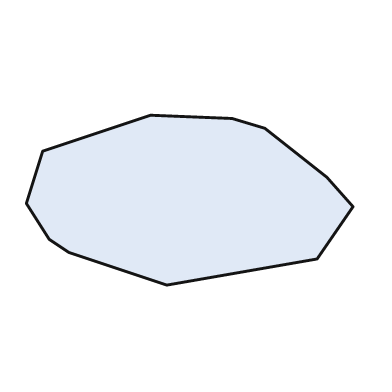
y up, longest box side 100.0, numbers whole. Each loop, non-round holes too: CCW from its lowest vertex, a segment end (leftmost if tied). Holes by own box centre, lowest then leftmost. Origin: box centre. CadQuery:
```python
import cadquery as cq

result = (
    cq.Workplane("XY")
    .moveTo(-7.0, -26.0)
    .lineTo(39.0, -18.0)
    .lineTo(50.0, -2.0)
    .lineTo(42.0, 7.0)
    .lineTo(23.0, 22.0)
    .lineTo(13.0, 25.0)
    .lineTo(-12.0, 26.0)
    .lineTo(-45.0, 15.0)
    .lineTo(-50.0, -1.0)
    .lineTo(-43.0, -12.0)
    .lineTo(-37.0, -16.0)
    .close()
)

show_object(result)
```